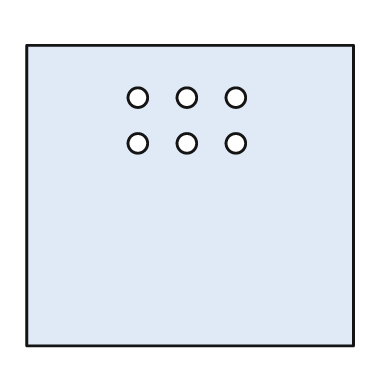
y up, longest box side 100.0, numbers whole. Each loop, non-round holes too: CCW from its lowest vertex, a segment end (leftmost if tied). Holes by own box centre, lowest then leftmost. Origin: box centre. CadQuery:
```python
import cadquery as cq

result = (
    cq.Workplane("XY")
    .moveTo(-50.0, -46.0)
    .lineTo(50.0, -46.0)
    .lineTo(50.0, 46.0)
    .lineTo(-50.0, 46.0)
    .close()
    .moveTo(-16.0, 16.0)
    .circle(3.0)
    .moveTo(-1.0, 16.0)
    .circle(3.0)
    .moveTo(14.0, 16.0)
    .circle(3.0)
    .moveTo(-16.0, 30.0)
    .circle(3.0)
    .moveTo(-1.0, 30.0)
    .circle(3.0)
    .moveTo(14.0, 30.0)
    .circle(3.0)
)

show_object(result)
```